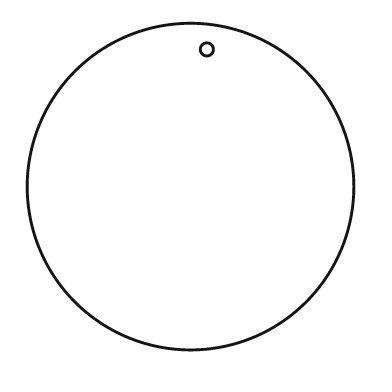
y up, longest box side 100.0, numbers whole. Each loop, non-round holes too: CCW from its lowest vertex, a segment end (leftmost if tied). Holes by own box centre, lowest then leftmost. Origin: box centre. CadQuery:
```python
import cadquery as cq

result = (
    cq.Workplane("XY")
    .moveTo(0.0, 0.0)
    .circle(50.0)
    .moveTo(5.0, 42.0)
    .circle(2.0)
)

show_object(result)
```